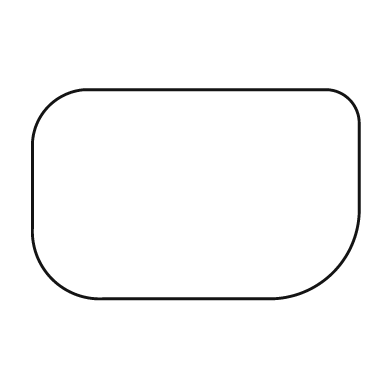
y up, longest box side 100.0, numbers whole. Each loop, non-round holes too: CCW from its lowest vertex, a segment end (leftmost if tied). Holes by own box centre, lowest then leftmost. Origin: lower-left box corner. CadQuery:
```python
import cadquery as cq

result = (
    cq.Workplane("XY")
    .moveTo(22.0, 0.0)
    .lineTo(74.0, 0.0)
    .threePointArc((92.0, 8.0), (100.0, 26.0))
    .lineTo(100.0, 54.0)
    .threePointArc((97.0, 61.0), (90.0, 64.0))
    .lineTo(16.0, 64.0)
    .threePointArc((5.0, 59.0), (0.0, 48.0))
    .lineTo(0.0, 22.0)
    .threePointArc((6.0, 6.0), (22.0, 0.0))
    .close()
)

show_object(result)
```